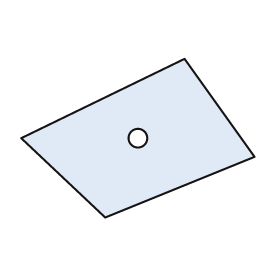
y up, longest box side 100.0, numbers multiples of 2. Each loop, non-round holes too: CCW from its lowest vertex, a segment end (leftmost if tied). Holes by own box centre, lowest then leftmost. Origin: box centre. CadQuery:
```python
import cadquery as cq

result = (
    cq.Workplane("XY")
    .moveTo(-14.0, -34.0)
    .lineTo(50.0, -8.0)
    .lineTo(20.0, 34.0)
    .lineTo(-50.0, 0.0)
    .close()
    .moveTo(0.0, 0.0)
    .circle(4.0)
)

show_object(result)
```